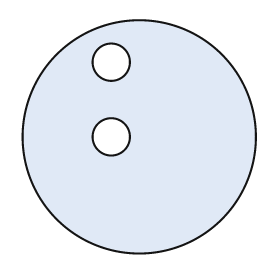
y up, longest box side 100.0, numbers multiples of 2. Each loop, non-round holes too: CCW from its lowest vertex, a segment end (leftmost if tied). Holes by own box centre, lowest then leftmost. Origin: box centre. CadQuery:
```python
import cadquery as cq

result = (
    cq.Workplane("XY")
    .moveTo(0.0, 0.0)
    .circle(50.0)
    .moveTo(-12.0, 0.0)
    .circle(8.0)
    .moveTo(-12.0, 32.0)
    .circle(8.0)
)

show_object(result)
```